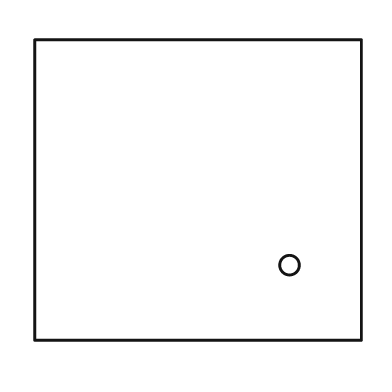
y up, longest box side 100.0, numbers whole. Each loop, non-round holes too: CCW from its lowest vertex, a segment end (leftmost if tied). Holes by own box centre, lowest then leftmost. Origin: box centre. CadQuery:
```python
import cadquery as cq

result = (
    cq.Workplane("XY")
    .moveTo(-50.0, -46.0)
    .lineTo(50.0, -46.0)
    .lineTo(50.0, 46.0)
    .lineTo(-50.0, 46.0)
    .close()
    .moveTo(28.0, -23.0)
    .circle(3.0)
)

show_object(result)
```